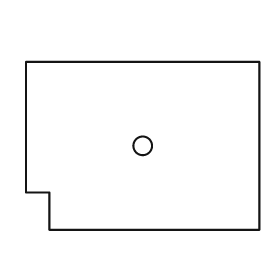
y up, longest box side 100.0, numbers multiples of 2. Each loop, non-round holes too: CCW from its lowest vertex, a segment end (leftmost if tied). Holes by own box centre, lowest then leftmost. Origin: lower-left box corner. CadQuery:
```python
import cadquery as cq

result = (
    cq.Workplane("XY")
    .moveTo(10.0, 0.0)
    .lineTo(100.0, 0.0)
    .lineTo(100.0, 72.0)
    .lineTo(0.0, 72.0)
    .lineTo(0.0, 16.0)
    .lineTo(10.0, 16.0)
    .close()
    .moveTo(50.0, 36.0)
    .circle(4.0)
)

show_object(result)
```